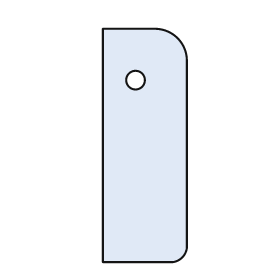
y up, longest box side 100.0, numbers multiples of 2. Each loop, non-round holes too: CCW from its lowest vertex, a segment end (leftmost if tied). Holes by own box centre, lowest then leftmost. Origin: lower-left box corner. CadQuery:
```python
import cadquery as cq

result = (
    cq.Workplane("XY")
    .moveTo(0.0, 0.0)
    .lineTo(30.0, 0.0)
    .threePointArc((34.0, 2.0), (36.0, 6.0))
    .lineTo(36.0, 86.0)
    .threePointArc((32.0, 96.0), (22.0, 100.0))
    .lineTo(0.0, 100.0)
    .close()
    .moveTo(14.0, 78.0)
    .circle(4.0)
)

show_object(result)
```